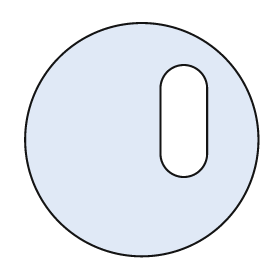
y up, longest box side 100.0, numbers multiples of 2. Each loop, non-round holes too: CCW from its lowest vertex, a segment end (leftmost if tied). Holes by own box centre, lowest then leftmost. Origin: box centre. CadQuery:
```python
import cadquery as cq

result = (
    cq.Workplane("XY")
    .moveTo(0.0, 0.0)
    .circle(50.0)
    .moveTo(8.0, -6.0)
    .threePointArc((18.0, -16.0), (28.0, -6.0))
    .lineTo(28.0, 22.0)
    .threePointArc((18.0, 32.0), (8.0, 22.0))
    .close()
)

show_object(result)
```